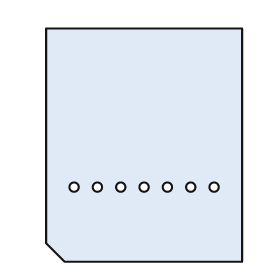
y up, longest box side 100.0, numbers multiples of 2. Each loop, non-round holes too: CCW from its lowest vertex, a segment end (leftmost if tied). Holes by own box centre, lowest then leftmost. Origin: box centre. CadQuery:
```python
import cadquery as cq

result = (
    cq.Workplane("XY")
    .moveTo(-34.0, -50.0)
    .lineTo(42.0, -50.0)
    .lineTo(42.0, 50.0)
    .lineTo(-42.0, 50.0)
    .lineTo(-42.0, -42.0)
    .close()
    .moveTo(-30.0, -18.0)
    .circle(2.0)
    .moveTo(-20.0, -18.0)
    .circle(2.0)
    .moveTo(-10.0, -18.0)
    .circle(2.0)
    .moveTo(0.0, -18.0)
    .circle(2.0)
    .moveTo(10.0, -18.0)
    .circle(2.0)
    .moveTo(20.0, -18.0)
    .circle(2.0)
    .moveTo(30.0, -18.0)
    .circle(2.0)
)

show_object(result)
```